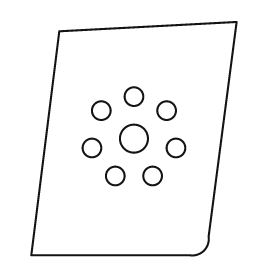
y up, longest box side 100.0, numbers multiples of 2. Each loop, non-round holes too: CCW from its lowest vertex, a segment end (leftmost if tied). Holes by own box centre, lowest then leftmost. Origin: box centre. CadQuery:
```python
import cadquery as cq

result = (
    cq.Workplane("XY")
    .moveTo(-44.0, -50.0)
    .lineTo(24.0, -50.0)
    .threePointArc((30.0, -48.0), (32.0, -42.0))
    .lineTo(44.0, 50.0)
    .lineTo(-32.0, 46.0)
    .close()
    .moveTo(-8.0, -16.0)
    .circle(4.0)
    .moveTo(8.0, -16.0)
    .circle(4.0)
    .moveTo(-18.0, -4.0)
    .circle(4.0)
    .moveTo(18.0, -4.0)
    .circle(4.0)
    .moveTo(0.0, 0.0)
    .circle(6.0)
    .moveTo(-14.0, 12.0)
    .circle(4.0)
    .moveTo(14.0, 12.0)
    .circle(4.0)
    .moveTo(0.0, 18.0)
    .circle(4.0)
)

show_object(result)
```